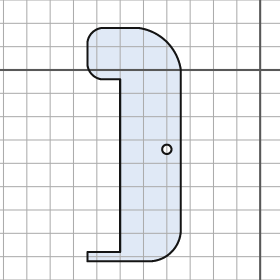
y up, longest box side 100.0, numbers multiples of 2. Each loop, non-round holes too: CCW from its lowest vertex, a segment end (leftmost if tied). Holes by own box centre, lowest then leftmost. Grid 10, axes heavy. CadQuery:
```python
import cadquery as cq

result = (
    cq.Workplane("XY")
    .moveTo(-74.0, -82.0)
    .lineTo(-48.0, -82.0)
    .threePointArc((-38.0, -78.0), (-34.0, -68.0))
    .lineTo(-34.0, 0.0)
    .threePointArc((-40.0, 12.0), (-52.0, 18.0))
    .lineTo(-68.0, 18.0)
    .threePointArc((-72.0, 16.0), (-74.0, 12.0))
    .lineTo(-74.0, 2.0)
    .threePointArc((-72.0, -2.0), (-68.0, -4.0))
    .lineTo(-60.0, -4.0)
    .lineTo(-60.0, -78.0)
    .lineTo(-74.0, -78.0)
    .close()
    .moveTo(-40.0, -34.0)
    .circle(2.0)
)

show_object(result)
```